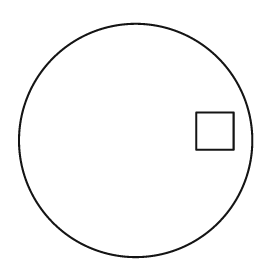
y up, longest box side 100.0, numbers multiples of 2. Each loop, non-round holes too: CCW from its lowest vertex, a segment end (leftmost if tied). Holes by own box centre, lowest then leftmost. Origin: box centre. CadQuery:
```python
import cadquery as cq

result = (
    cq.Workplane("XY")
    .moveTo(0.0, 0.0)
    .circle(50.0)
    .moveTo(26.0, -4.0)
    .lineTo(42.0, -4.0)
    .lineTo(42.0, 12.0)
    .lineTo(26.0, 12.0)
    .close()
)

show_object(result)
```